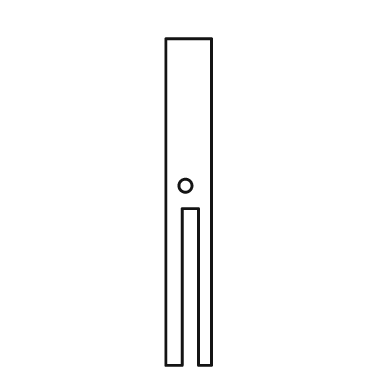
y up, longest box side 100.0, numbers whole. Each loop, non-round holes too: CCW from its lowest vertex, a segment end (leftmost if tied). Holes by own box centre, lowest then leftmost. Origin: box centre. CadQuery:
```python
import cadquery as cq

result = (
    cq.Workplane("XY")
    .moveTo(-7.0, -50.0)
    .lineTo(-2.0, -50.0)
    .lineTo(-2.0, -2.0)
    .lineTo(3.0, -2.0)
    .lineTo(3.0, -50.0)
    .lineTo(7.0, -50.0)
    .lineTo(7.0, 50.0)
    .lineTo(-7.0, 50.0)
    .close()
    .moveTo(-1.0, 5.0)
    .circle(2.0)
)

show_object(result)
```